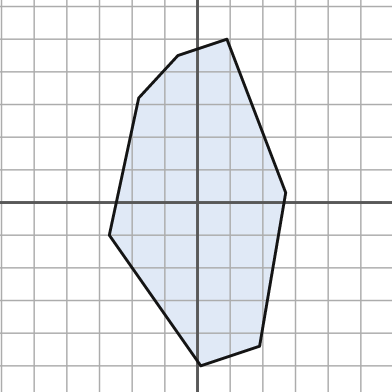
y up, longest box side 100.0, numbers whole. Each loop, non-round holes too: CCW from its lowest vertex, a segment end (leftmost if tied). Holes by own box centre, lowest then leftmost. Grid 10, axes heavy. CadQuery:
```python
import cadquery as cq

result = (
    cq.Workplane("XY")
    .moveTo(1.0, -50.0)
    .lineTo(19.0, -44.0)
    .lineTo(27.0, 3.0)
    .lineTo(9.0, 50.0)
    .lineTo(-6.0, 45.0)
    .lineTo(-18.0, 32.0)
    .lineTo(-27.0, -10.0)
    .close()
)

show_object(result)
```